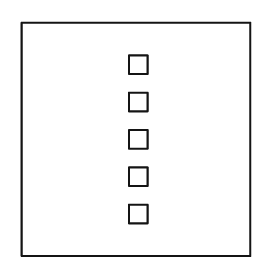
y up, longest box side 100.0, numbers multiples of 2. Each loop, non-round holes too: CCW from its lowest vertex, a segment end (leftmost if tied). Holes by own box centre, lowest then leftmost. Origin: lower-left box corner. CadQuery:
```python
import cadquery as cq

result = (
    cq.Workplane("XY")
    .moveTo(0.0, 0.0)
    .lineTo(98.0, 0.0)
    .lineTo(98.0, 100.0)
    .lineTo(0.0, 100.0)
    .close()
    .moveTo(46.0, 14.0)
    .lineTo(54.0, 14.0)
    .lineTo(54.0, 22.0)
    .lineTo(46.0, 22.0)
    .close()
    .moveTo(46.0, 30.0)
    .lineTo(54.0, 30.0)
    .lineTo(54.0, 38.0)
    .lineTo(46.0, 38.0)
    .close()
    .moveTo(46.0, 46.0)
    .lineTo(54.0, 46.0)
    .lineTo(54.0, 54.0)
    .lineTo(46.0, 54.0)
    .close()
    .moveTo(46.0, 62.0)
    .lineTo(54.0, 62.0)
    .lineTo(54.0, 70.0)
    .lineTo(46.0, 70.0)
    .close()
    .moveTo(46.0, 78.0)
    .lineTo(54.0, 78.0)
    .lineTo(54.0, 86.0)
    .lineTo(46.0, 86.0)
    .close()
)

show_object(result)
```